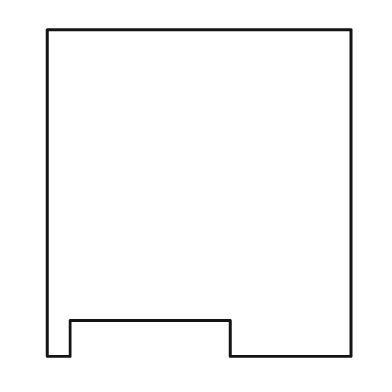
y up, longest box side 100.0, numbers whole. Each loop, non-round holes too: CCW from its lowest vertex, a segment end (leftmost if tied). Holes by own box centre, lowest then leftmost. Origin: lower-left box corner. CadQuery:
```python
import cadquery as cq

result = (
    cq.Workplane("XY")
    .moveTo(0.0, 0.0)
    .lineTo(7.0, 0.0)
    .lineTo(7.0, 11.0)
    .lineTo(56.0, 11.0)
    .lineTo(56.0, 0.0)
    .lineTo(93.0, 0.0)
    .lineTo(93.0, 100.0)
    .lineTo(0.0, 100.0)
    .close()
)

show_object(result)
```